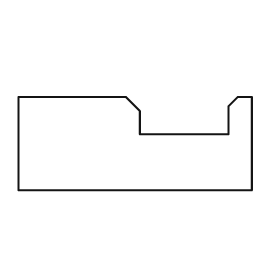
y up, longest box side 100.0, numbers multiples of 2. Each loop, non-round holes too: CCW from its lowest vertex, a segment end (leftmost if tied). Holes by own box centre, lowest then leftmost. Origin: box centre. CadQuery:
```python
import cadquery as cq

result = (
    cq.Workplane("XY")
    .moveTo(-50.0, -20.0)
    .lineTo(50.0, -20.0)
    .lineTo(50.0, 20.0)
    .lineTo(44.0, 20.0)
    .lineTo(40.0, 16.0)
    .lineTo(40.0, 4.0)
    .lineTo(2.0, 4.0)
    .lineTo(2.0, 14.0)
    .lineTo(-4.0, 20.0)
    .lineTo(-50.0, 20.0)
    .close()
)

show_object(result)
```